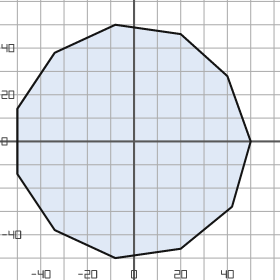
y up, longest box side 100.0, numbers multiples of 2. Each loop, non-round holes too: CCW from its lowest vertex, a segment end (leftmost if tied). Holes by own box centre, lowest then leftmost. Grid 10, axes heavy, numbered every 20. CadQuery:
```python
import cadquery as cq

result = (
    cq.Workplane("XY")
    .moveTo(-8.0, -50.0)
    .lineTo(20.0, -46.0)
    .lineTo(42.0, -28.0)
    .lineTo(50.0, 0.0)
    .lineTo(40.0, 28.0)
    .lineTo(20.0, 46.0)
    .lineTo(-8.0, 50.0)
    .lineTo(-34.0, 38.0)
    .lineTo(-50.0, 14.0)
    .lineTo(-50.0, -14.0)
    .lineTo(-34.0, -38.0)
    .close()
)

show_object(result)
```